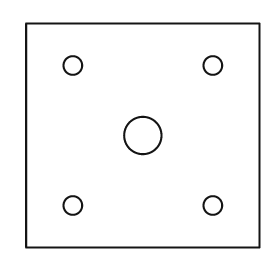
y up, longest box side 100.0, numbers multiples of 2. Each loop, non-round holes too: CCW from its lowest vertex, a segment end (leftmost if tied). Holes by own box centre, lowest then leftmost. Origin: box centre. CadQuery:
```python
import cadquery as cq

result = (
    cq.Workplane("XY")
    .moveTo(-50.0, -48.0)
    .lineTo(50.0, -48.0)
    .lineTo(50.0, 48.0)
    .lineTo(-50.0, 48.0)
    .close()
    .moveTo(-30.0, -30.0)
    .circle(4.0)
    .moveTo(30.0, -30.0)
    .circle(4.0)
    .moveTo(0.0, 0.0)
    .circle(8.0)
    .moveTo(-30.0, 30.0)
    .circle(4.0)
    .moveTo(30.0, 30.0)
    .circle(4.0)
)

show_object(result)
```